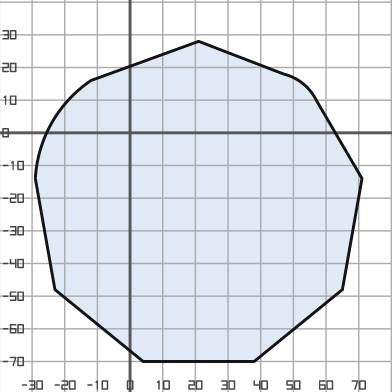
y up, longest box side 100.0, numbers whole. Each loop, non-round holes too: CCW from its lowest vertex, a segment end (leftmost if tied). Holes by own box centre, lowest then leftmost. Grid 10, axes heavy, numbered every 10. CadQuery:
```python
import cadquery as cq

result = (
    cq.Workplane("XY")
    .moveTo(4.0, -70.0)
    .lineTo(38.0, -70.0)
    .lineTo(65.0, -48.0)
    .lineTo(71.0, -14.0)
    .lineTo(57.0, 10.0)
    .threePointArc((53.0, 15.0), (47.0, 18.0))
    .lineTo(21.0, 28.0)
    .lineTo(-12.0, 16.0)
    .threePointArc((-24.0, 3.0), (-29.0, -14.0))
    .lineTo(-23.0, -48.0)
    .close()
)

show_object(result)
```